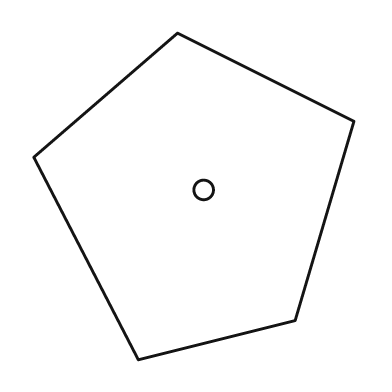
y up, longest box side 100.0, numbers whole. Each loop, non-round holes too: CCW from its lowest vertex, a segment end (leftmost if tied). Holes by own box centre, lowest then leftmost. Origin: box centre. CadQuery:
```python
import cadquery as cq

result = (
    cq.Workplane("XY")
    .moveTo(-17.0, -50.0)
    .lineTo(31.0, -38.0)
    .lineTo(49.0, 23.0)
    .lineTo(-5.0, 50.0)
    .lineTo(-49.0, 12.0)
    .close()
    .moveTo(3.0, 2.0)
    .circle(3.0)
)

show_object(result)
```